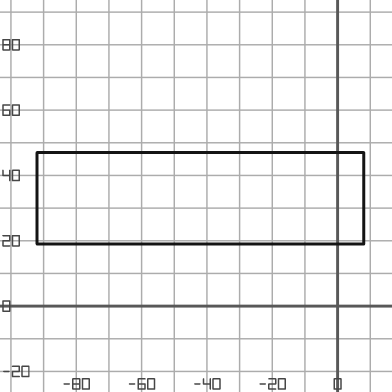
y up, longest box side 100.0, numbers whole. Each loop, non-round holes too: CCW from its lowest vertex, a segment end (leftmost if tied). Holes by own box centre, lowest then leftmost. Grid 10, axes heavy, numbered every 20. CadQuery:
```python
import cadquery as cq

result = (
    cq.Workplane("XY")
    .moveTo(-92.0, 19.0)
    .lineTo(8.0, 19.0)
    .lineTo(8.0, 47.0)
    .lineTo(-92.0, 47.0)
    .close()
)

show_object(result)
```